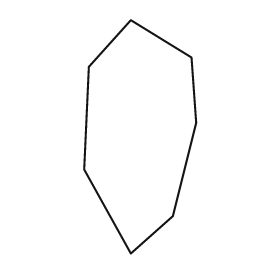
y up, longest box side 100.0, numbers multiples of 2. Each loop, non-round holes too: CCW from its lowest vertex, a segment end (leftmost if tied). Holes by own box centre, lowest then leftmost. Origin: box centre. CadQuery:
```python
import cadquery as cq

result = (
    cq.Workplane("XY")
    .moveTo(-4.0, -50.0)
    .lineTo(14.0, -34.0)
    .lineTo(24.0, 6.0)
    .lineTo(22.0, 34.0)
    .lineTo(-4.0, 50.0)
    .lineTo(-22.0, 30.0)
    .lineTo(-24.0, -14.0)
    .close()
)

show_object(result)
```